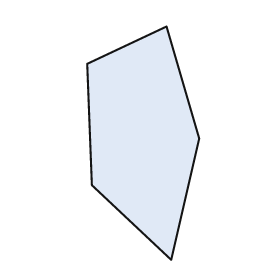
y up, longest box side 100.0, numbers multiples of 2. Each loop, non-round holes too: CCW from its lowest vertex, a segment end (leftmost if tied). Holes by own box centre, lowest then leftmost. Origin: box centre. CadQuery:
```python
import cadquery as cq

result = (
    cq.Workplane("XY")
    .moveTo(12.0, -50.0)
    .lineTo(24.0, 2.0)
    .lineTo(10.0, 50.0)
    .lineTo(-24.0, 34.0)
    .lineTo(-22.0, -18.0)
    .close()
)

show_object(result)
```